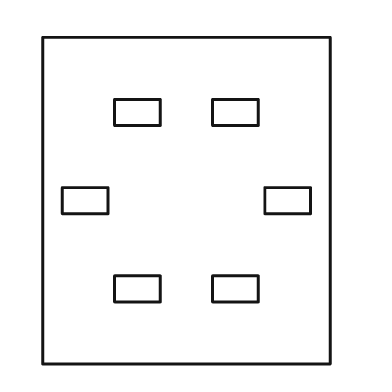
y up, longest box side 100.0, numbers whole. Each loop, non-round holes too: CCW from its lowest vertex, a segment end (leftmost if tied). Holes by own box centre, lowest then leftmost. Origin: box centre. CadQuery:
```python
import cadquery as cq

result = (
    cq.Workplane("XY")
    .moveTo(-44.0, -50.0)
    .lineTo(44.0, -50.0)
    .lineTo(44.0, 50.0)
    .lineTo(-44.0, 50.0)
    .close()
    .moveTo(-22.0, -31.0)
    .lineTo(-8.0, -31.0)
    .lineTo(-8.0, -23.0)
    .lineTo(-22.0, -23.0)
    .close()
    .moveTo(8.0, -31.0)
    .lineTo(22.0, -31.0)
    .lineTo(22.0, -23.0)
    .lineTo(8.0, -23.0)
    .close()
    .moveTo(-38.0, -4.0)
    .lineTo(-24.0, -4.0)
    .lineTo(-24.0, 4.0)
    .lineTo(-38.0, 4.0)
    .close()
    .moveTo(24.0, -4.0)
    .lineTo(38.0, -4.0)
    .lineTo(38.0, 4.0)
    .lineTo(24.0, 4.0)
    .close()
    .moveTo(-22.0, 23.0)
    .lineTo(-8.0, 23.0)
    .lineTo(-8.0, 31.0)
    .lineTo(-22.0, 31.0)
    .close()
    .moveTo(8.0, 23.0)
    .lineTo(22.0, 23.0)
    .lineTo(22.0, 31.0)
    .lineTo(8.0, 31.0)
    .close()
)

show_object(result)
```